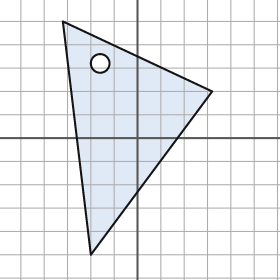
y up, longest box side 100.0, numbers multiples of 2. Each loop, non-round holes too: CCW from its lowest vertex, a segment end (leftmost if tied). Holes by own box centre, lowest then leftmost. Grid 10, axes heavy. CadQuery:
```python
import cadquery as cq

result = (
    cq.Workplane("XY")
    .moveTo(-20.0, -50.0)
    .lineTo(32.0, 20.0)
    .lineTo(-32.0, 50.0)
    .close()
    .moveTo(-16.0, 32.0)
    .circle(4.0)
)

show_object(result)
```